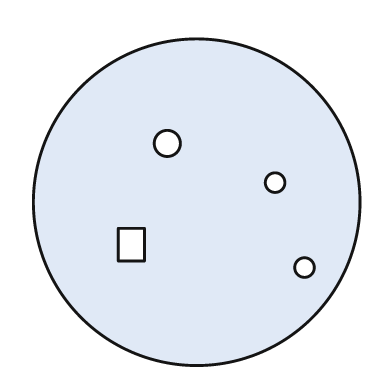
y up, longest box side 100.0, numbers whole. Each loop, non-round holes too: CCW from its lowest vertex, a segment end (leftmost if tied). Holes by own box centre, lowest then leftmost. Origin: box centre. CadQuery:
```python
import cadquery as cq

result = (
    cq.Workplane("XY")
    .moveTo(0.0, 0.0)
    .circle(50.0)
    .moveTo(33.0, -20.0)
    .circle(3.0)
    .moveTo(-24.0, -18.0)
    .lineTo(-16.0, -18.0)
    .lineTo(-16.0, -8.0)
    .lineTo(-24.0, -8.0)
    .close()
    .moveTo(24.0, 6.0)
    .circle(3.0)
    .moveTo(-9.0, 18.0)
    .circle(4.0)
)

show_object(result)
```